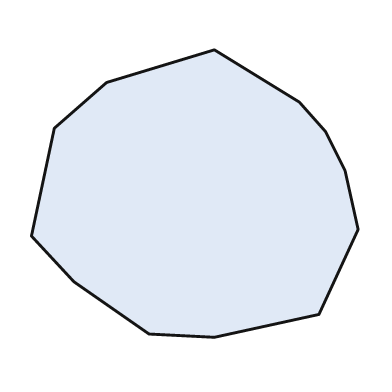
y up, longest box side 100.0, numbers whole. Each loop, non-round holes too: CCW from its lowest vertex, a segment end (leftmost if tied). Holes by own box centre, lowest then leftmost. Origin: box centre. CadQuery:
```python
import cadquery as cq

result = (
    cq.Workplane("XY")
    .moveTo(6.0, -44.0)
    .lineTo(38.0, -37.0)
    .lineTo(50.0, -11.0)
    .lineTo(46.0, 7.0)
    .lineTo(40.0, 19.0)
    .lineTo(32.0, 28.0)
    .lineTo(6.0, 44.0)
    .lineTo(-27.0, 34.0)
    .lineTo(-43.0, 20.0)
    .lineTo(-50.0, -13.0)
    .lineTo(-37.0, -27.0)
    .lineTo(-14.0, -43.0)
    .close()
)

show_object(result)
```